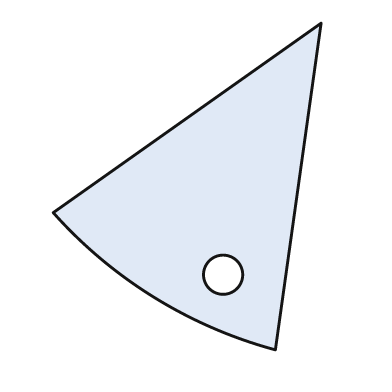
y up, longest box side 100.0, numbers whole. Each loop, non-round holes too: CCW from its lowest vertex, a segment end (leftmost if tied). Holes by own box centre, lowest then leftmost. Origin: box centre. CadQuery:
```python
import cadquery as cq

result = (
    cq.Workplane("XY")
    .moveTo(27.0, -50.0)
    .lineTo(41.0, 50.0)
    .lineTo(-41.0, -8.0)
    .threePointArc((-10.0, -34.0), (27.0, -50.0))
    .close()
    .moveTo(11.0, -27.0)
    .circle(6.0)
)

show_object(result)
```